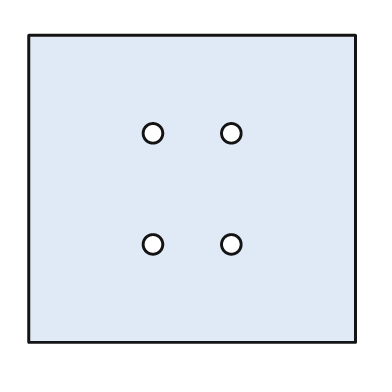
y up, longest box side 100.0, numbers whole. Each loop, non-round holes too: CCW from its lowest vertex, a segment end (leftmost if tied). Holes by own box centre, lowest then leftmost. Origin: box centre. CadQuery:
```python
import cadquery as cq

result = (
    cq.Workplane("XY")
    .moveTo(-50.0, -47.0)
    .lineTo(50.0, -47.0)
    .lineTo(50.0, 47.0)
    .lineTo(-50.0, 47.0)
    .close()
    .moveTo(-12.0, -17.0)
    .circle(3.0)
    .moveTo(12.0, -17.0)
    .circle(3.0)
    .moveTo(-12.0, 17.0)
    .circle(3.0)
    .moveTo(12.0, 17.0)
    .circle(3.0)
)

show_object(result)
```